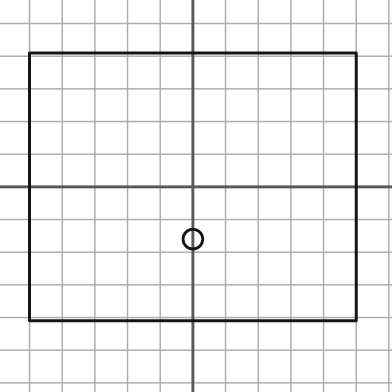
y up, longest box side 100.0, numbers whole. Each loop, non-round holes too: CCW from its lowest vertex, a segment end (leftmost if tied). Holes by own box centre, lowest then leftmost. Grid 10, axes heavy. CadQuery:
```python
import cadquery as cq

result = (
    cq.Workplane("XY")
    .moveTo(-50.0, -41.0)
    .lineTo(50.0, -41.0)
    .lineTo(50.0, 41.0)
    .lineTo(-50.0, 41.0)
    .close()
    .moveTo(0.0, -16.0)
    .circle(3.0)
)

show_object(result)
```